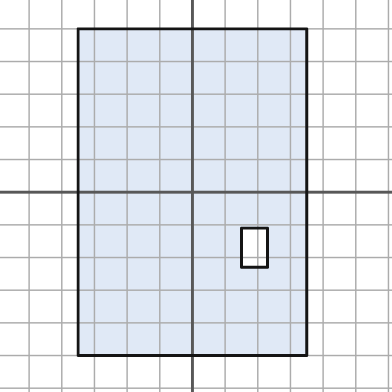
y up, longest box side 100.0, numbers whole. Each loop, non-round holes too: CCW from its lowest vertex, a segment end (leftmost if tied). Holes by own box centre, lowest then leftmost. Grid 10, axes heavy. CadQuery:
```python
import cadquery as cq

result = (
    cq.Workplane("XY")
    .moveTo(-35.0, -50.0)
    .lineTo(35.0, -50.0)
    .lineTo(35.0, 50.0)
    .lineTo(-35.0, 50.0)
    .close()
    .moveTo(15.0, -23.0)
    .lineTo(23.0, -23.0)
    .lineTo(23.0, -11.0)
    .lineTo(15.0, -11.0)
    .close()
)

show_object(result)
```